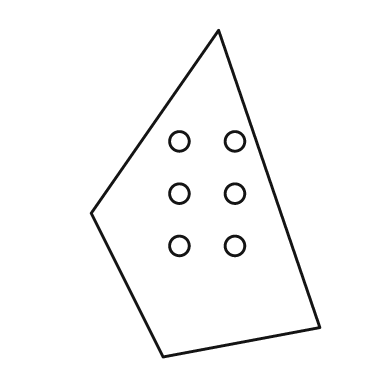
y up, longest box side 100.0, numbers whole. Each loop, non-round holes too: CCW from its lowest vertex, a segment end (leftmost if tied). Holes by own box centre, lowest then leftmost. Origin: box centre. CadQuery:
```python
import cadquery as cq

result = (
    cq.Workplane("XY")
    .moveTo(-13.0, -50.0)
    .lineTo(35.0, -41.0)
    .lineTo(4.0, 50.0)
    .lineTo(-35.0, -6.0)
    .close()
    .moveTo(-8.0, -16.0)
    .circle(3.0)
    .moveTo(9.0, -16.0)
    .circle(3.0)
    .moveTo(-8.0, 0.0)
    .circle(3.0)
    .moveTo(9.0, 0.0)
    .circle(3.0)
    .moveTo(-8.0, 16.0)
    .circle(3.0)
    .moveTo(9.0, 16.0)
    .circle(3.0)
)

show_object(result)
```